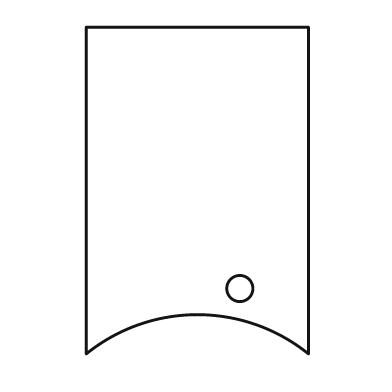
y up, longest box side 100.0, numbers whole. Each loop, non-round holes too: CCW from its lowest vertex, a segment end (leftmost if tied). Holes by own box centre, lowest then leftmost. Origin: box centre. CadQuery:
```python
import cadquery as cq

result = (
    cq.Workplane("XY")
    .moveTo(-34.0, -50.0)
    .threePointArc((0.0, -38.0), (34.0, -50.0))
    .lineTo(34.0, 50.0)
    .lineTo(-34.0, 50.0)
    .close()
    .moveTo(13.0, -30.0)
    .circle(4.0)
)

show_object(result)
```